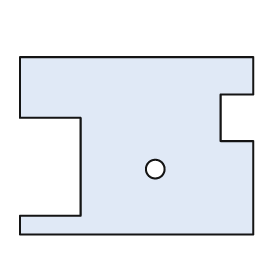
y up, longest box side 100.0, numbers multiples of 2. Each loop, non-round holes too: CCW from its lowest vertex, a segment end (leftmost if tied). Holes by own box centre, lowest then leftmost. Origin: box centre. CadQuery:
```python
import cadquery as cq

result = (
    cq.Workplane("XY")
    .moveTo(-50.0, -38.0)
    .lineTo(50.0, -38.0)
    .lineTo(50.0, 2.0)
    .lineTo(36.0, 2.0)
    .lineTo(36.0, 22.0)
    .lineTo(50.0, 22.0)
    .lineTo(50.0, 38.0)
    .lineTo(-50.0, 38.0)
    .lineTo(-50.0, 12.0)
    .lineTo(-24.0, 12.0)
    .lineTo(-24.0, -30.0)
    .lineTo(-50.0, -30.0)
    .close()
    .moveTo(8.0, -10.0)
    .circle(4.0)
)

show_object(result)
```